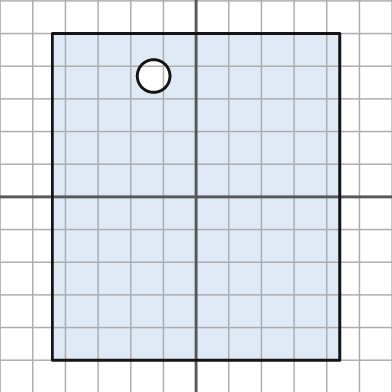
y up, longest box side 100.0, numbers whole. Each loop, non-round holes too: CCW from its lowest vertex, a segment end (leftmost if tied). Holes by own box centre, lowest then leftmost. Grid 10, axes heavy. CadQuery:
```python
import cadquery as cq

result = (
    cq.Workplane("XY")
    .moveTo(-44.0, -50.0)
    .lineTo(44.0, -50.0)
    .lineTo(44.0, 50.0)
    .lineTo(-44.0, 50.0)
    .close()
    .moveTo(-13.0, 37.0)
    .circle(5.0)
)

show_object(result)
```